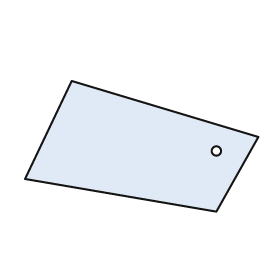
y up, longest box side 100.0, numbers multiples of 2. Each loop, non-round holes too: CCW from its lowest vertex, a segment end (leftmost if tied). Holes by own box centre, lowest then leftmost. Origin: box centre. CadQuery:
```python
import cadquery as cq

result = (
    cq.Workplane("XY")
    .moveTo(32.0, -28.0)
    .lineTo(50.0, 4.0)
    .lineTo(-30.0, 28.0)
    .lineTo(-50.0, -14.0)
    .close()
    .moveTo(32.0, -2.0)
    .circle(2.0)
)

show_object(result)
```